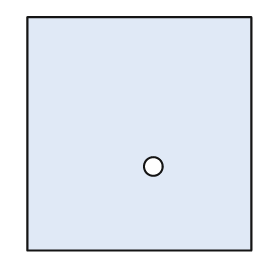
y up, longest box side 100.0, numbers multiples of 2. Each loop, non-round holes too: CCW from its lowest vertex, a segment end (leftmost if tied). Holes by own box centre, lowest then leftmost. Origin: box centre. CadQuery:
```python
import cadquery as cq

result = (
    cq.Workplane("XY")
    .moveTo(-48.0, -50.0)
    .lineTo(48.0, -50.0)
    .lineTo(48.0, 50.0)
    .lineTo(-48.0, 50.0)
    .close()
    .moveTo(6.0, -14.0)
    .circle(4.0)
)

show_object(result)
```